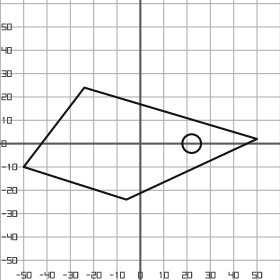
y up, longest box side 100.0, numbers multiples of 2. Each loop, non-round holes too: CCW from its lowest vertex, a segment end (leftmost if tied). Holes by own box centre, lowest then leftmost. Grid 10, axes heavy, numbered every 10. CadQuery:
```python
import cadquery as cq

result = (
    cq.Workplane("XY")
    .moveTo(-6.0, -24.0)
    .lineTo(50.0, 2.0)
    .lineTo(-24.0, 24.0)
    .lineTo(-50.0, -10.0)
    .close()
    .moveTo(22.0, 0.0)
    .circle(4.0)
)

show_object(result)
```